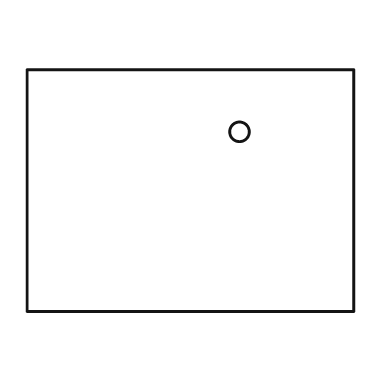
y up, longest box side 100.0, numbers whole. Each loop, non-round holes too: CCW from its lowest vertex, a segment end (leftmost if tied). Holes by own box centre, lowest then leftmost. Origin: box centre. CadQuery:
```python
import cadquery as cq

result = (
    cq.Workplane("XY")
    .moveTo(-50.0, -37.0)
    .lineTo(50.0, -37.0)
    .lineTo(50.0, 37.0)
    .lineTo(-50.0, 37.0)
    .close()
    .moveTo(15.0, 18.0)
    .circle(3.0)
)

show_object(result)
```